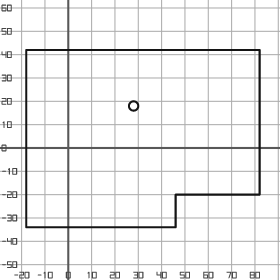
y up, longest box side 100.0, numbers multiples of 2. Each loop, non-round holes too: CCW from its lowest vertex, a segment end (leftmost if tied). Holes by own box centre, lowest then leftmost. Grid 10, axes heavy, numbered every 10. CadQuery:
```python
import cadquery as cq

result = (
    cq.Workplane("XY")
    .moveTo(-18.0, -34.0)
    .lineTo(46.0, -34.0)
    .lineTo(46.0, -20.0)
    .lineTo(82.0, -20.0)
    .lineTo(82.0, 42.0)
    .lineTo(-18.0, 42.0)
    .close()
    .moveTo(28.0, 18.0)
    .circle(2.0)
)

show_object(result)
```